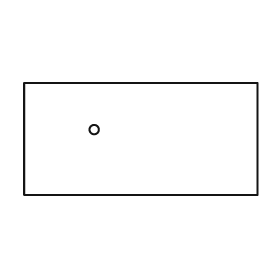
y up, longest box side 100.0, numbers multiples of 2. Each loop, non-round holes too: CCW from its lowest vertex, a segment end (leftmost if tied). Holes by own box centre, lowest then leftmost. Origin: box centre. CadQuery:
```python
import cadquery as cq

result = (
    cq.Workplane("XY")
    .moveTo(-50.0, -24.0)
    .lineTo(50.0, -24.0)
    .lineTo(50.0, 24.0)
    .lineTo(-50.0, 24.0)
    .close()
    .moveTo(-20.0, 4.0)
    .circle(2.0)
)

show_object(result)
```